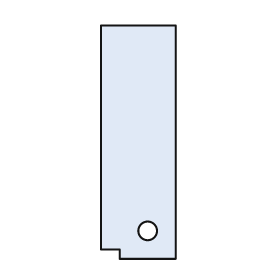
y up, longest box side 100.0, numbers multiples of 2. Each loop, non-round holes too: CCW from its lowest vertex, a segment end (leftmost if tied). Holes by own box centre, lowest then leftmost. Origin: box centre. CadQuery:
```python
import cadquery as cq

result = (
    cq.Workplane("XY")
    .moveTo(-8.0, -50.0)
    .lineTo(16.0, -50.0)
    .lineTo(16.0, 50.0)
    .lineTo(-16.0, 50.0)
    .lineTo(-16.0, -46.0)
    .lineTo(-8.0, -46.0)
    .close()
    .moveTo(4.0, -38.0)
    .circle(4.0)
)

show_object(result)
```